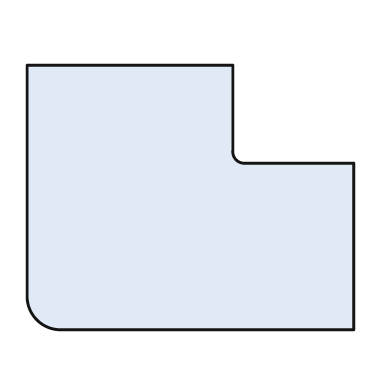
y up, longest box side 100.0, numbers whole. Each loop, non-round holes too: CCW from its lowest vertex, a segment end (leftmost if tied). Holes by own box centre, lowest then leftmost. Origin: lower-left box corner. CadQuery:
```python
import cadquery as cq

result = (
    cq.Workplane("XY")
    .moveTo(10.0, 0.0)
    .lineTo(100.0, 0.0)
    .lineTo(100.0, 51.0)
    .lineTo(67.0, 51.0)
    .threePointArc((64.0, 52.0), (63.0, 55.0))
    .lineTo(63.0, 81.0)
    .lineTo(0.0, 81.0)
    .lineTo(0.0, 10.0)
    .threePointArc((3.0, 3.0), (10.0, 0.0))
    .close()
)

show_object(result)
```